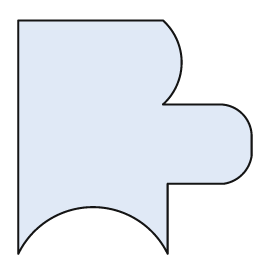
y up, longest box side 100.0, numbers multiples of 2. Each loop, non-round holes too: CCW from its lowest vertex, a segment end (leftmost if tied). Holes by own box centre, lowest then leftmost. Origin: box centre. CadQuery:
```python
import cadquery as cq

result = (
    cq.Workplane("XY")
    .moveTo(-50.0, -50.0)
    .threePointArc((-18.0, -30.0), (14.0, -50.0))
    .lineTo(14.0, -20.0)
    .lineTo(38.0, -20.0)
    .threePointArc((46.0, -16.0), (50.0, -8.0))
    .lineTo(50.0, 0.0)
    .threePointArc((46.0, 10.0), (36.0, 14.0))
    .lineTo(12.0, 14.0)
    .threePointArc((20.0, 32.0), (12.0, 50.0))
    .lineTo(-50.0, 50.0)
    .close()
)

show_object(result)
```